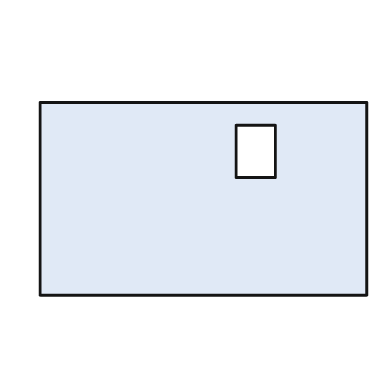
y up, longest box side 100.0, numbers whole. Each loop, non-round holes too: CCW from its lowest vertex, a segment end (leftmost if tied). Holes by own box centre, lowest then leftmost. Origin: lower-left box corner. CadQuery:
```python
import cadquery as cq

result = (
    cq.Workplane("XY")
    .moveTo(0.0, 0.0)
    .lineTo(100.0, 0.0)
    .lineTo(100.0, 59.0)
    .lineTo(0.0, 59.0)
    .close()
    .moveTo(60.0, 36.0)
    .lineTo(72.0, 36.0)
    .lineTo(72.0, 52.0)
    .lineTo(60.0, 52.0)
    .close()
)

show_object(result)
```